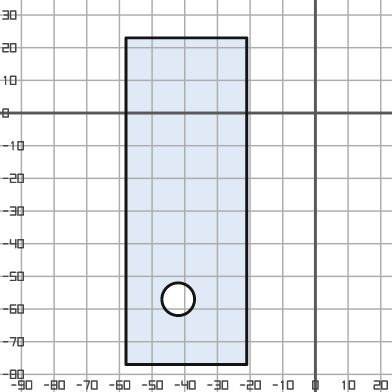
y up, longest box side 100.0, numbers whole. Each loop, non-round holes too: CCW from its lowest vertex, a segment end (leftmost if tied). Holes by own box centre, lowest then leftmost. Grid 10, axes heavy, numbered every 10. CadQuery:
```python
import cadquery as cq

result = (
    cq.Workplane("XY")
    .moveTo(-58.0, -77.0)
    .lineTo(-21.0, -77.0)
    .lineTo(-21.0, 23.0)
    .lineTo(-58.0, 23.0)
    .close()
    .moveTo(-42.0, -57.0)
    .circle(5.0)
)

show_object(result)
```